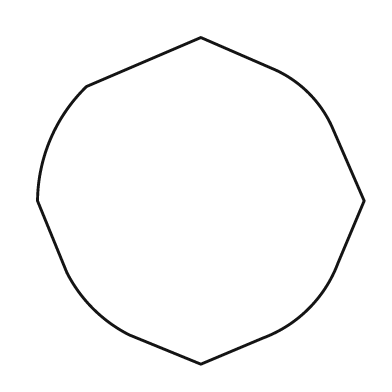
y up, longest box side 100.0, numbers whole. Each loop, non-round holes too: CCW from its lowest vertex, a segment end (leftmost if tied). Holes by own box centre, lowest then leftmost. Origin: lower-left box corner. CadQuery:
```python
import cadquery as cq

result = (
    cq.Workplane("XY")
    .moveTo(50.0, 0.0)
    .lineTo(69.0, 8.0)
    .threePointArc((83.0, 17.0), (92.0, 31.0))
    .lineTo(100.0, 50.0)
    .lineTo(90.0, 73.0)
    .threePointArc((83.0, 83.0), (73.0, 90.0))
    .lineTo(50.0, 100.0)
    .lineTo(15.0, 85.0)
    .threePointArc((4.0, 69.0), (0.0, 50.0))
    .lineTo(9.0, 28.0)
    .threePointArc((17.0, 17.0), (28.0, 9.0))
    .close()
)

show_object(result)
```